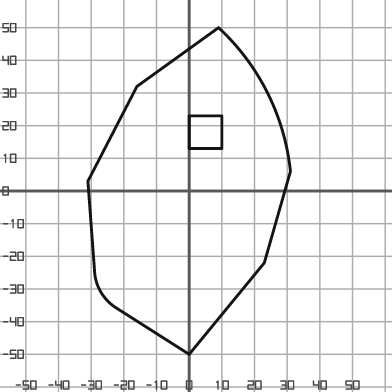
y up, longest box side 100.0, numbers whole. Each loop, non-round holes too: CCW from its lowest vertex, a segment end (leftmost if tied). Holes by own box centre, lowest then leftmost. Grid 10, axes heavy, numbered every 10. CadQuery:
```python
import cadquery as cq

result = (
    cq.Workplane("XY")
    .moveTo(0.0, -50.0)
    .lineTo(23.0, -22.0)
    .lineTo(31.0, 6.0)
    .threePointArc((24.0, 30.0), (9.0, 50.0))
    .lineTo(-16.0, 32.0)
    .lineTo(-31.0, 3.0)
    .lineTo(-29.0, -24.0)
    .threePointArc((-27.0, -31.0), (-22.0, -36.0))
    .close()
    .moveTo(0.0, 13.0)
    .lineTo(10.0, 13.0)
    .lineTo(10.0, 23.0)
    .lineTo(0.0, 23.0)
    .close()
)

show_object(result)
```